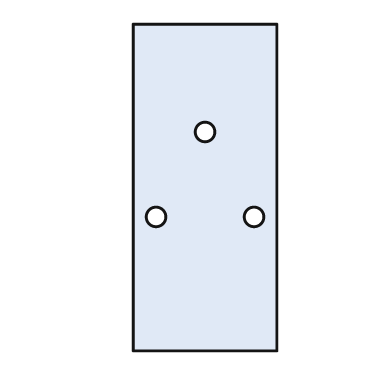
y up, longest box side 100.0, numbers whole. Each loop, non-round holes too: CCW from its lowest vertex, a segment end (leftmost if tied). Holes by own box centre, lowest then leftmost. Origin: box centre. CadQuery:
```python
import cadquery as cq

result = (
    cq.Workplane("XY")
    .moveTo(-22.0, -50.0)
    .lineTo(22.0, -50.0)
    .lineTo(22.0, 50.0)
    .lineTo(-22.0, 50.0)
    .close()
    .moveTo(-15.0, -9.0)
    .circle(3.0)
    .moveTo(15.0, -9.0)
    .circle(3.0)
    .moveTo(0.0, 17.0)
    .circle(3.0)
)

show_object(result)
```